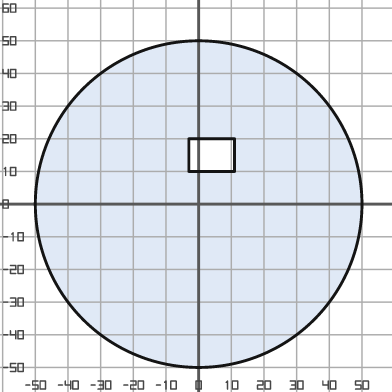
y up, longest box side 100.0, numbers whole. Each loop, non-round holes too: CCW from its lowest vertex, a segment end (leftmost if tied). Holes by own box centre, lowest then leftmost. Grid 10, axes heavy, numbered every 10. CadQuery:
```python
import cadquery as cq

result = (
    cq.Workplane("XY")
    .moveTo(0.0, 0.0)
    .circle(50.0)
    .moveTo(-3.0, 10.0)
    .lineTo(11.0, 10.0)
    .lineTo(11.0, 20.0)
    .lineTo(-3.0, 20.0)
    .close()
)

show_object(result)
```